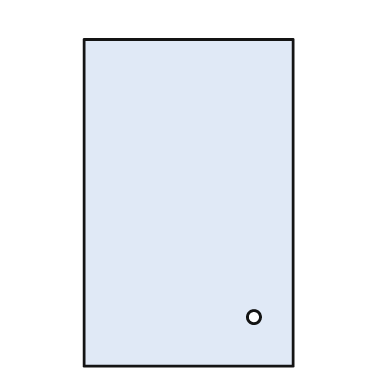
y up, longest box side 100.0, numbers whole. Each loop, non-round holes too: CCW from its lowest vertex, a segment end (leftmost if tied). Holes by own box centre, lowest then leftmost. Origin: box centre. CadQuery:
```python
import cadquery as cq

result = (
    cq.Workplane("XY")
    .moveTo(-32.0, -50.0)
    .lineTo(32.0, -50.0)
    .lineTo(32.0, 50.0)
    .lineTo(-32.0, 50.0)
    .close()
    .moveTo(20.0, -35.0)
    .circle(2.0)
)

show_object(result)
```